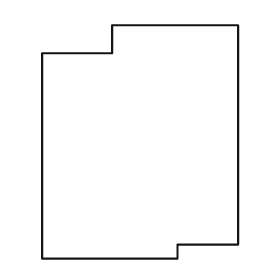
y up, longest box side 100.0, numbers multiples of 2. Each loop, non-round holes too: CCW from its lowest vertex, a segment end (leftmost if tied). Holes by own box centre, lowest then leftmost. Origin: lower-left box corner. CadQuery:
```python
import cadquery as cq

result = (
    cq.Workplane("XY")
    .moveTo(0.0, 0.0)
    .lineTo(58.0, 0.0)
    .lineTo(58.0, 6.0)
    .lineTo(84.0, 6.0)
    .lineTo(84.0, 100.0)
    .lineTo(30.0, 100.0)
    .lineTo(30.0, 88.0)
    .lineTo(0.0, 88.0)
    .close()
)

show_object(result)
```